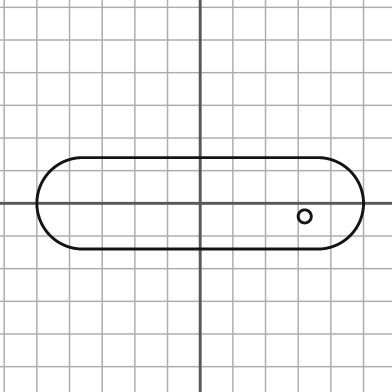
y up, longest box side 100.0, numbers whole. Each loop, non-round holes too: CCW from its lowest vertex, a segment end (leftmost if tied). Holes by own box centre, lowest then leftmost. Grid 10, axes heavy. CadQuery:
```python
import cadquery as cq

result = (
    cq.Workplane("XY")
    .moveTo(-36.0, -14.0)
    .lineTo(36.0, -14.0)
    .threePointArc((50.0, 0.0), (36.0, 14.0))
    .lineTo(-36.0, 14.0)
    .threePointArc((-50.0, 0.0), (-36.0, -14.0))
    .close()
    .moveTo(32.0, -4.0)
    .circle(2.0)
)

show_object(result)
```